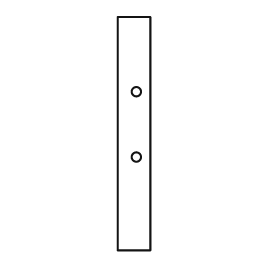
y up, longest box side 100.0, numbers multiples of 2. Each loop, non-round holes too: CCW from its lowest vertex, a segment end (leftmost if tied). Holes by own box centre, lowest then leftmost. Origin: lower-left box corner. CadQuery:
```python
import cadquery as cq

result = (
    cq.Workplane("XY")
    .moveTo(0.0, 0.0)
    .lineTo(14.0, 0.0)
    .lineTo(14.0, 100.0)
    .lineTo(0.0, 100.0)
    .close()
    .moveTo(8.0, 40.0)
    .circle(2.0)
    .moveTo(8.0, 68.0)
    .circle(2.0)
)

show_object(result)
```